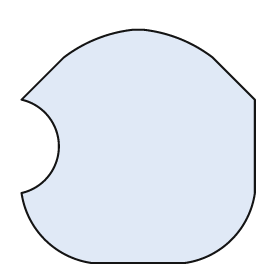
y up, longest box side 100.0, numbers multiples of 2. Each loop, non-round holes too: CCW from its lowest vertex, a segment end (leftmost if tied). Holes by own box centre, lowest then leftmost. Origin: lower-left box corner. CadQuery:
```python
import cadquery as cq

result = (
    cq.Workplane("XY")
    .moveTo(30.0, 0.0)
    .lineTo(70.0, 0.0)
    .threePointArc((90.0, 10.0), (100.0, 30.0))
    .lineTo(100.0, 70.0)
    .lineTo(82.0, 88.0)
    .threePointArc((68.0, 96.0), (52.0, 100.0))
    .lineTo(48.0, 100.0)
    .threePointArc((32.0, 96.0), (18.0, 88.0))
    .lineTo(0.0, 70.0)
    .threePointArc((16.0, 50.0), (0.0, 30.0))
    .threePointArc((10.0, 10.0), (30.0, 0.0))
    .close()
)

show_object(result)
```